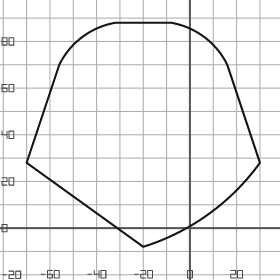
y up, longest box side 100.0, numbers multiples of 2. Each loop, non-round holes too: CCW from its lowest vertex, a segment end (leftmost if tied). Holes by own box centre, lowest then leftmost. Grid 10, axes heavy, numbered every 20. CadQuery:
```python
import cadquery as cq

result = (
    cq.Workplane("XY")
    .moveTo(-20.0, -8.0)
    .threePointArc((8.0, 6.0), (30.0, 28.0))
    .lineTo(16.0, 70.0)
    .threePointArc((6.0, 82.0), (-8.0, 88.0))
    .lineTo(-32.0, 88.0)
    .threePointArc((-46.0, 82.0), (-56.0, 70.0))
    .lineTo(-70.0, 28.0)
    .close()
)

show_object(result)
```